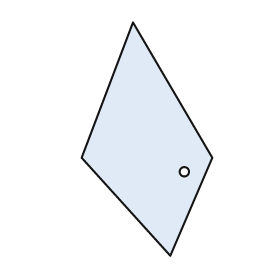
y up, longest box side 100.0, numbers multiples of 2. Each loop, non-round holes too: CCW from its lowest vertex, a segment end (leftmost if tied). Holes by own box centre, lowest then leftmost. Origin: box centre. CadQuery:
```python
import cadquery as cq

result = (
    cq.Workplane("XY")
    .moveTo(10.0, -50.0)
    .lineTo(28.0, -8.0)
    .lineTo(-6.0, 50.0)
    .lineTo(-28.0, -8.0)
    .close()
    .moveTo(16.0, -14.0)
    .circle(2.0)
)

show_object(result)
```